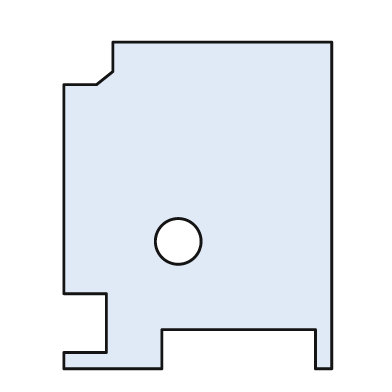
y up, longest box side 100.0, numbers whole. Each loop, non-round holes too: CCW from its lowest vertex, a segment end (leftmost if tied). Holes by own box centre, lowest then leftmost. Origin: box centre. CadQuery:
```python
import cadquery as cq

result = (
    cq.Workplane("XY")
    .moveTo(-41.0, -50.0)
    .lineTo(-11.0, -50.0)
    .lineTo(-11.0, -38.0)
    .lineTo(36.0, -38.0)
    .lineTo(36.0, -50.0)
    .lineTo(41.0, -50.0)
    .lineTo(41.0, 50.0)
    .lineTo(-26.0, 50.0)
    .lineTo(-26.0, 41.0)
    .lineTo(-31.0, 37.0)
    .lineTo(-41.0, 37.0)
    .lineTo(-41.0, -27.0)
    .lineTo(-28.0, -27.0)
    .lineTo(-28.0, -45.0)
    .lineTo(-41.0, -45.0)
    .close()
    .moveTo(-6.0, -11.0)
    .circle(7.0)
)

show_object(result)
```